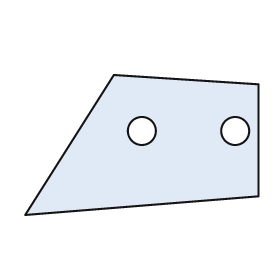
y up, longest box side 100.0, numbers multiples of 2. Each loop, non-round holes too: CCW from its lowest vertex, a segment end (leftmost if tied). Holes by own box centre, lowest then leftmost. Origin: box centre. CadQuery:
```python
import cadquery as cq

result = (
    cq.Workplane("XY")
    .moveTo(-50.0, -30.0)
    .lineTo(50.0, -22.0)
    .lineTo(50.0, 26.0)
    .lineTo(-12.0, 30.0)
    .close()
    .moveTo(0.0, 6.0)
    .circle(6.0)
    .moveTo(40.0, 6.0)
    .circle(6.0)
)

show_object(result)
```